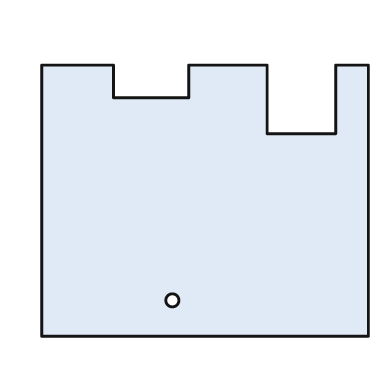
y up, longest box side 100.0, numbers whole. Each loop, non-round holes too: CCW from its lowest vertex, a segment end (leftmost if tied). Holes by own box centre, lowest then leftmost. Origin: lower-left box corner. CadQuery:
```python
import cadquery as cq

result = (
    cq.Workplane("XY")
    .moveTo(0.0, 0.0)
    .lineTo(100.0, 0.0)
    .lineTo(100.0, 83.0)
    .lineTo(90.0, 83.0)
    .lineTo(90.0, 62.0)
    .lineTo(69.0, 62.0)
    .lineTo(69.0, 83.0)
    .lineTo(45.0, 83.0)
    .lineTo(45.0, 73.0)
    .lineTo(22.0, 73.0)
    .lineTo(22.0, 83.0)
    .lineTo(0.0, 83.0)
    .close()
    .moveTo(40.0, 11.0)
    .circle(2.0)
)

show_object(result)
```